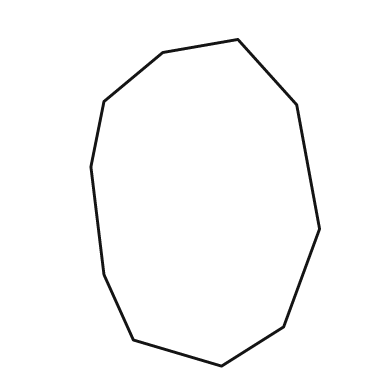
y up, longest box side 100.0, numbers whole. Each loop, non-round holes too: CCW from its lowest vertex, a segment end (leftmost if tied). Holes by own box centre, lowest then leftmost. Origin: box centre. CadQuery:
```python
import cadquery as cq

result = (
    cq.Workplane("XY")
    .moveTo(5.0, -50.0)
    .lineTo(24.0, -38.0)
    .lineTo(35.0, -8.0)
    .lineTo(28.0, 30.0)
    .lineTo(10.0, 50.0)
    .lineTo(-13.0, 46.0)
    .lineTo(-31.0, 31.0)
    .lineTo(-35.0, 11.0)
    .lineTo(-31.0, -22.0)
    .lineTo(-22.0, -42.0)
    .close()
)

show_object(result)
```